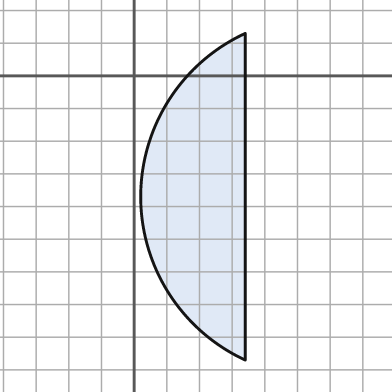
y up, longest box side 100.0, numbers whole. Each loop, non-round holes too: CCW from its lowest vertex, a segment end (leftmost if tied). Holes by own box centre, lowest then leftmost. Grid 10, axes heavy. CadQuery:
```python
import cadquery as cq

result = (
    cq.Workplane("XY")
    .moveTo(34.0, -87.0)
    .lineTo(34.0, 13.0)
    .threePointArc((2.0, -37.0), (34.0, -87.0))
    .close()
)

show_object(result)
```